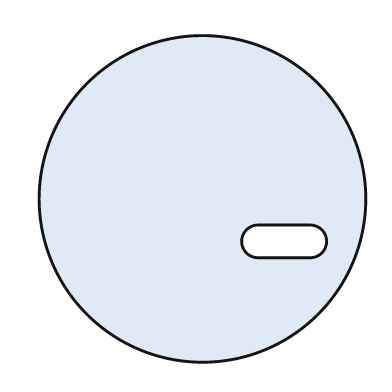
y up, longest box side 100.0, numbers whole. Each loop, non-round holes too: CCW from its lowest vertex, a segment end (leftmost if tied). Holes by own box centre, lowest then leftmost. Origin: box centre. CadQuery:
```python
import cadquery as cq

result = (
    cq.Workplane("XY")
    .moveTo(0.0, 0.0)
    .circle(50.0)
    .moveTo(17.0, -18.0)
    .lineTo(33.0, -18.0)
    .threePointArc((38.0, -13.0), (33.0, -8.0))
    .lineTo(17.0, -8.0)
    .threePointArc((12.0, -13.0), (17.0, -18.0))
    .close()
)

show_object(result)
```